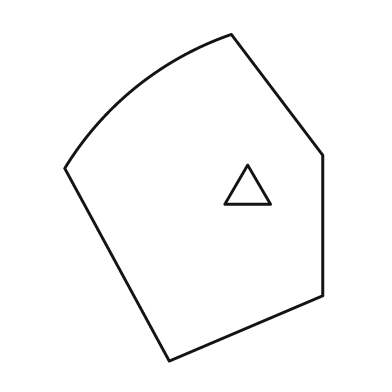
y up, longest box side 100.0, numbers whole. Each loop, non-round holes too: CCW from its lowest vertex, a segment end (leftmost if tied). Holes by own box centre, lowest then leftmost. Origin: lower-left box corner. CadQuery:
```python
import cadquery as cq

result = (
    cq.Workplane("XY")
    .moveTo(32.0, 0.0)
    .lineTo(79.0, 20.0)
    .lineTo(79.0, 63.0)
    .lineTo(51.0, 100.0)
    .threePointArc((22.0, 84.0), (0.0, 59.0))
    .close()
    .moveTo(49.0, 48.0)
    .lineTo(63.0, 48.0)
    .lineTo(56.0, 60.0)
    .close()
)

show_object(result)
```